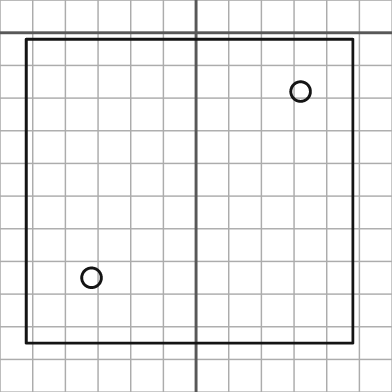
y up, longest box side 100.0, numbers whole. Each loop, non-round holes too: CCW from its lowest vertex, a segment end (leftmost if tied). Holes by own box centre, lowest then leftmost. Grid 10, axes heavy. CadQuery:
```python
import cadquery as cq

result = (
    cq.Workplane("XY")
    .moveTo(-52.0, -95.0)
    .lineTo(48.0, -95.0)
    .lineTo(48.0, -2.0)
    .lineTo(-52.0, -2.0)
    .close()
    .moveTo(-32.0, -75.0)
    .circle(3.0)
    .moveTo(32.0, -18.0)
    .circle(3.0)
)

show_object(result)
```